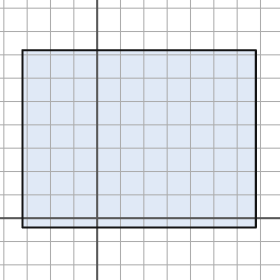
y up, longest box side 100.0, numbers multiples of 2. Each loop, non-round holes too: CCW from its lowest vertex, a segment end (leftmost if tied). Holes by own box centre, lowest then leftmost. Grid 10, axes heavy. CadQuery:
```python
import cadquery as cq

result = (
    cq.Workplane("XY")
    .moveTo(-32.0, -4.0)
    .lineTo(68.0, -4.0)
    .lineTo(68.0, 72.0)
    .lineTo(-32.0, 72.0)
    .close()
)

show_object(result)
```